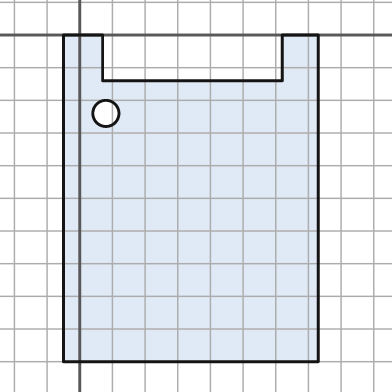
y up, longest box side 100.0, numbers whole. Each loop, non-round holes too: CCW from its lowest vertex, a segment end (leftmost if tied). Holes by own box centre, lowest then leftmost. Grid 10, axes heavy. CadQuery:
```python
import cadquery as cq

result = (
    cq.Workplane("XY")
    .moveTo(-5.0, -100.0)
    .lineTo(73.0, -100.0)
    .lineTo(73.0, 0.0)
    .lineTo(62.0, 0.0)
    .lineTo(62.0, -14.0)
    .lineTo(7.0, -14.0)
    .lineTo(7.0, 0.0)
    .lineTo(-5.0, 0.0)
    .close()
    .moveTo(8.0, -24.0)
    .circle(4.0)
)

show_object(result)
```